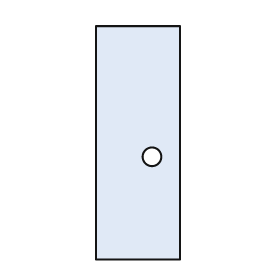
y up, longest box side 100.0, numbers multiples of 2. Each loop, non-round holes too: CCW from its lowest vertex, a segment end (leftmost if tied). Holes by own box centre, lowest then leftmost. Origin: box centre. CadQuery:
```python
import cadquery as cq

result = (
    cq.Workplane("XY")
    .moveTo(-18.0, -50.0)
    .lineTo(18.0, -50.0)
    .lineTo(18.0, 50.0)
    .lineTo(-18.0, 50.0)
    .close()
    .moveTo(6.0, -6.0)
    .circle(4.0)
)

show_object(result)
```